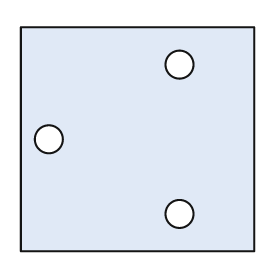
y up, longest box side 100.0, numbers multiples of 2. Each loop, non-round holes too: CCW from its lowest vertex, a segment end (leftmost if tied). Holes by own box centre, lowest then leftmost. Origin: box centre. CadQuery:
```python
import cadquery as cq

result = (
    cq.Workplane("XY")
    .moveTo(-50.0, -48.0)
    .lineTo(50.0, -48.0)
    .lineTo(50.0, 48.0)
    .lineTo(-50.0, 48.0)
    .close()
    .moveTo(18.0, -32.0)
    .circle(6.0)
    .moveTo(-38.0, 0.0)
    .circle(6.0)
    .moveTo(18.0, 32.0)
    .circle(6.0)
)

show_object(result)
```